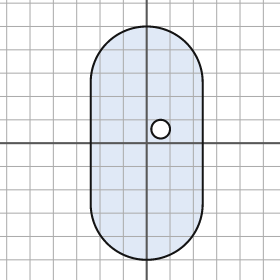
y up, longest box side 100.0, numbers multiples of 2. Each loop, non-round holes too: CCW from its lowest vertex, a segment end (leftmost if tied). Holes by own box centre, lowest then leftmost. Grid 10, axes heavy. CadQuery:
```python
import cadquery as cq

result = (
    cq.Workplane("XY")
    .moveTo(-24.0, -26.0)
    .threePointArc((0.0, -50.0), (24.0, -26.0))
    .lineTo(24.0, 26.0)
    .threePointArc((0.0, 50.0), (-24.0, 26.0))
    .close()
    .moveTo(6.0, 6.0)
    .circle(4.0)
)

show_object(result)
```